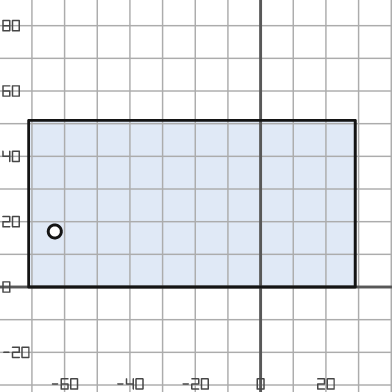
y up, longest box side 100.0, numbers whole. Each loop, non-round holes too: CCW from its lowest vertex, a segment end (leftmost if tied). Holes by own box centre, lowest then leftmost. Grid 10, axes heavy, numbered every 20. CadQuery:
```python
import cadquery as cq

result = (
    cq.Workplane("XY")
    .moveTo(-71.0, 0.0)
    .lineTo(29.0, 0.0)
    .lineTo(29.0, 51.0)
    .lineTo(-71.0, 51.0)
    .close()
    .moveTo(-63.0, 17.0)
    .circle(2.0)
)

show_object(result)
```